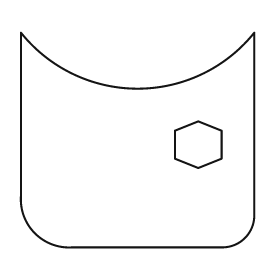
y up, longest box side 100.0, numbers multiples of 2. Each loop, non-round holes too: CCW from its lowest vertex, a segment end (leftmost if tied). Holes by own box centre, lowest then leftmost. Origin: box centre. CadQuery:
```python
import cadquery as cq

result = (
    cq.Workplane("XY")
    .moveTo(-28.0, -46.0)
    .lineTo(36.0, -46.0)
    .threePointArc((46.0, -42.0), (50.0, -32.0))
    .lineTo(50.0, 46.0)
    .threePointArc((0.0, 22.0), (-50.0, 46.0))
    .lineTo(-50.0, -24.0)
    .threePointArc((-44.0, -40.0), (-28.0, -46.0))
    .close()
    .moveTo(26.0, -12.0)
    .lineTo(36.0, -8.0)
    .lineTo(36.0, 4.0)
    .lineTo(26.0, 8.0)
    .lineTo(16.0, 4.0)
    .lineTo(16.0, -8.0)
    .close()
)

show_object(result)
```